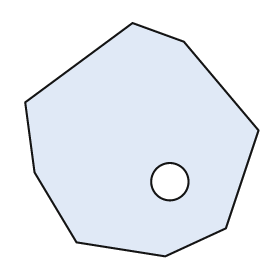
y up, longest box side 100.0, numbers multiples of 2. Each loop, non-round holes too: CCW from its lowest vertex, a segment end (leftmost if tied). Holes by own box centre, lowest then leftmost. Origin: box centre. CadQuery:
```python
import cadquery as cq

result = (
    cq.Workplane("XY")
    .moveTo(10.0, -50.0)
    .lineTo(36.0, -38.0)
    .lineTo(50.0, 4.0)
    .lineTo(18.0, 42.0)
    .lineTo(-4.0, 50.0)
    .lineTo(-50.0, 16.0)
    .lineTo(-46.0, -14.0)
    .lineTo(-28.0, -44.0)
    .close()
    .moveTo(12.0, -18.0)
    .circle(8.0)
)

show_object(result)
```